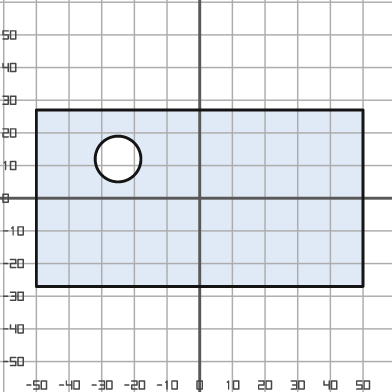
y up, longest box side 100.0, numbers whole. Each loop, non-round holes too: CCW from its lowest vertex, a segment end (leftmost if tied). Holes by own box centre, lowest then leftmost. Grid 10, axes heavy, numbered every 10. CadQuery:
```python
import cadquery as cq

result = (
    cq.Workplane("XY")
    .moveTo(-50.0, -27.0)
    .lineTo(50.0, -27.0)
    .lineTo(50.0, 27.0)
    .lineTo(-50.0, 27.0)
    .close()
    .moveTo(-25.0, 12.0)
    .circle(7.0)
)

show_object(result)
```